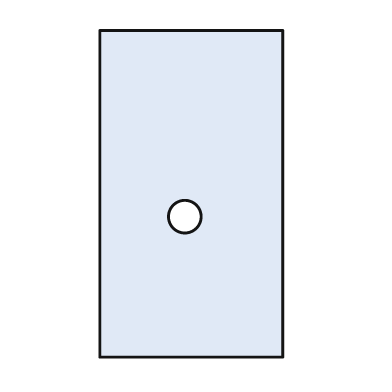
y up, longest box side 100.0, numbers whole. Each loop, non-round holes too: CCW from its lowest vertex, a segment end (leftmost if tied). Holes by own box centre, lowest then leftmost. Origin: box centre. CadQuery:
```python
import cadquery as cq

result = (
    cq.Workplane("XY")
    .moveTo(-28.0, -50.0)
    .lineTo(28.0, -50.0)
    .lineTo(28.0, 50.0)
    .lineTo(-28.0, 50.0)
    .close()
    .moveTo(-2.0, -7.0)
    .circle(5.0)
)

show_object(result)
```